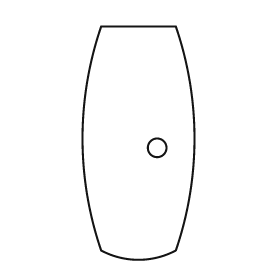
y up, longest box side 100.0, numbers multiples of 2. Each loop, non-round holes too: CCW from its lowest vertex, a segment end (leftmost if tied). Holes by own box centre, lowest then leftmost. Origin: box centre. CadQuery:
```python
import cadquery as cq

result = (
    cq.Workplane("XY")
    .moveTo(-16.0, -46.0)
    .threePointArc((0.0, -50.0), (16.0, -46.0))
    .threePointArc((24.0, 2.0), (16.0, 50.0))
    .lineTo(-16.0, 50.0)
    .threePointArc((-24.0, 2.0), (-16.0, -46.0))
    .close()
    .moveTo(8.0, -2.0)
    .circle(4.0)
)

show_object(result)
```